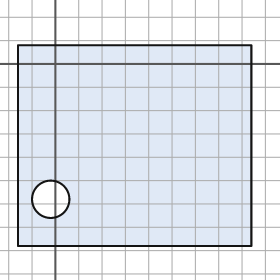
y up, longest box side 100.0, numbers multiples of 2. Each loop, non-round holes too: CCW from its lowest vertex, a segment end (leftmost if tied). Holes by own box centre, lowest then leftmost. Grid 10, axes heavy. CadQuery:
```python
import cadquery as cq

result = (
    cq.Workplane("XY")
    .moveTo(-16.0, -78.0)
    .lineTo(84.0, -78.0)
    .lineTo(84.0, 8.0)
    .lineTo(-16.0, 8.0)
    .close()
    .moveTo(-2.0, -58.0)
    .circle(8.0)
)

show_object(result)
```